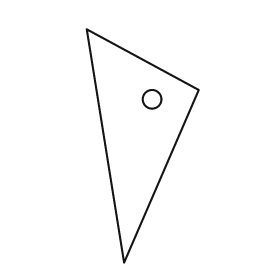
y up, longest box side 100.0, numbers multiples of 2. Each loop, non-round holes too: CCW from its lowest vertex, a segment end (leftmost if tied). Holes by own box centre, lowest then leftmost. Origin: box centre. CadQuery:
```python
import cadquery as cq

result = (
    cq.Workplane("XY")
    .moveTo(-8.0, -50.0)
    .lineTo(24.0, 24.0)
    .lineTo(-24.0, 50.0)
    .close()
    .moveTo(4.0, 20.0)
    .circle(4.0)
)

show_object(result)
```